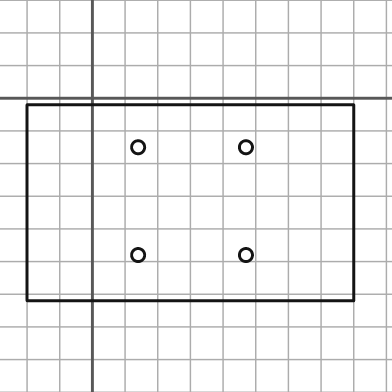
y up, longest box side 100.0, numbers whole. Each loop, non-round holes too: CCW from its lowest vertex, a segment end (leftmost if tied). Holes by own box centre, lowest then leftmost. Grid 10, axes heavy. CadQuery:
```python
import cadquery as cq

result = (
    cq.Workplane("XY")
    .moveTo(-20.0, -62.0)
    .lineTo(80.0, -62.0)
    .lineTo(80.0, -2.0)
    .lineTo(-20.0, -2.0)
    .close()
    .moveTo(14.0, -48.0)
    .circle(2.0)
    .moveTo(47.0, -48.0)
    .circle(2.0)
    .moveTo(14.0, -15.0)
    .circle(2.0)
    .moveTo(47.0, -15.0)
    .circle(2.0)
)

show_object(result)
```